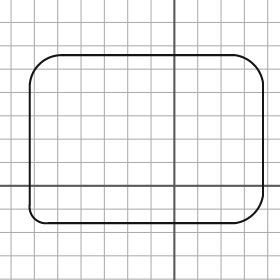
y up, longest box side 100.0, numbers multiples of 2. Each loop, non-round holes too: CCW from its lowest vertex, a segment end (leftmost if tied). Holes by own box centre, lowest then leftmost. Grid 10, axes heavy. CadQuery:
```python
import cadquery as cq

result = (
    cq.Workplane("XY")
    .moveTo(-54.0, -16.0)
    .lineTo(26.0, -16.0)
    .threePointArc((34.0, -12.0), (38.0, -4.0))
    .lineTo(38.0, 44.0)
    .threePointArc((34.0, 52.0), (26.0, 56.0))
    .lineTo(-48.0, 56.0)
    .threePointArc((-58.0, 52.0), (-62.0, 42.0))
    .lineTo(-62.0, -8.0)
    .threePointArc((-60.0, -14.0), (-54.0, -16.0))
    .close()
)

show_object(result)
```